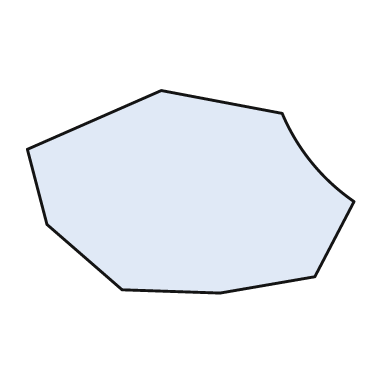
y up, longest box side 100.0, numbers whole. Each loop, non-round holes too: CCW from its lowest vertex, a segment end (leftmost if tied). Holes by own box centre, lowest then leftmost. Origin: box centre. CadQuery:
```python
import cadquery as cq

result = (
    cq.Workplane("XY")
    .moveTo(9.0, -31.0)
    .lineTo(38.0, -26.0)
    .lineTo(50.0, -3.0)
    .threePointArc((37.0, 9.0), (28.0, 24.0))
    .lineTo(-9.0, 31.0)
    .lineTo(-50.0, 13.0)
    .lineTo(-44.0, -10.0)
    .lineTo(-21.0, -30.0)
    .close()
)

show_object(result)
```